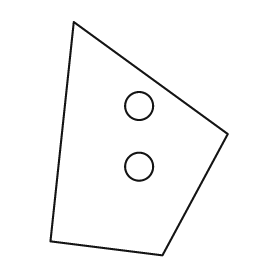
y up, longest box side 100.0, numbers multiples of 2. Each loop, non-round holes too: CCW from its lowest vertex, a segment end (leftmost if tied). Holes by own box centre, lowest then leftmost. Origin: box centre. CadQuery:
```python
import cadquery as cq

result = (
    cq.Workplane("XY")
    .moveTo(10.0, -50.0)
    .lineTo(38.0, 2.0)
    .lineTo(-28.0, 50.0)
    .lineTo(-38.0, -44.0)
    .close()
    .moveTo(0.0, -12.0)
    .circle(6.0)
    .moveTo(0.0, 14.0)
    .circle(6.0)
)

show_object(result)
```